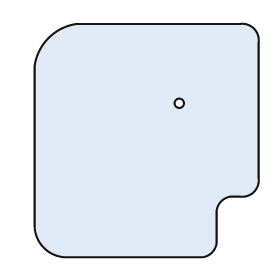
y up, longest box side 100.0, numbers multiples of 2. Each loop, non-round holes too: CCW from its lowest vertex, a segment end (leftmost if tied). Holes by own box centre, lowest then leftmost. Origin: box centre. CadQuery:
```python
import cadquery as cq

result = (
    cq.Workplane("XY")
    .moveTo(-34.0, -50.0)
    .lineTo(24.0, -50.0)
    .threePointArc((28.0, -48.0), (30.0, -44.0))
    .lineTo(30.0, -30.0)
    .threePointArc((32.0, -26.0), (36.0, -24.0))
    .lineTo(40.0, -24.0)
    .threePointArc((46.0, -22.0), (48.0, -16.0))
    .lineTo(48.0, 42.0)
    .threePointArc((46.0, 48.0), (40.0, 50.0))
    .lineTo(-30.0, 50.0)
    .threePointArc((-42.0, 44.0), (-48.0, 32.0))
    .lineTo(-48.0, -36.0)
    .threePointArc((-44.0, -46.0), (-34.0, -50.0))
    .close()
    .moveTo(14.0, 16.0)
    .circle(2.0)
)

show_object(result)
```